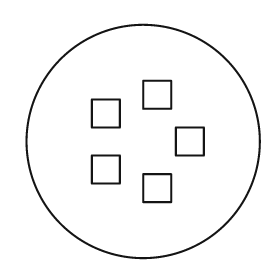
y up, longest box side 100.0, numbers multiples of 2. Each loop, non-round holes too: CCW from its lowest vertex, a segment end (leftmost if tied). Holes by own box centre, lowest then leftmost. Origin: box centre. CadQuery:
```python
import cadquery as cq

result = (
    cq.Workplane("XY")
    .moveTo(0.0, 0.0)
    .circle(50.0)
    .moveTo(0.0, -26.0)
    .lineTo(12.0, -26.0)
    .lineTo(12.0, -14.0)
    .lineTo(0.0, -14.0)
    .close()
    .moveTo(-22.0, -18.0)
    .lineTo(-10.0, -18.0)
    .lineTo(-10.0, -6.0)
    .lineTo(-22.0, -6.0)
    .close()
    .moveTo(14.0, -6.0)
    .lineTo(26.0, -6.0)
    .lineTo(26.0, 6.0)
    .lineTo(14.0, 6.0)
    .close()
    .moveTo(-22.0, 6.0)
    .lineTo(-10.0, 6.0)
    .lineTo(-10.0, 18.0)
    .lineTo(-22.0, 18.0)
    .close()
    .moveTo(0.0, 14.0)
    .lineTo(12.0, 14.0)
    .lineTo(12.0, 26.0)
    .lineTo(0.0, 26.0)
    .close()
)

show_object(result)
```